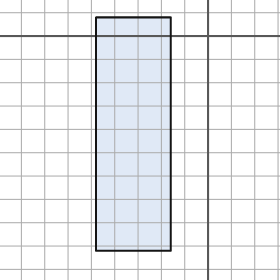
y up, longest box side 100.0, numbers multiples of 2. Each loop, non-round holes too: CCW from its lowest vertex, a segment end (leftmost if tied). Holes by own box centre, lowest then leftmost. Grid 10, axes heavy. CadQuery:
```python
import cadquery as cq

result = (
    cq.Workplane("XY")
    .moveTo(-48.0, -92.0)
    .lineTo(-16.0, -92.0)
    .lineTo(-16.0, 8.0)
    .lineTo(-48.0, 8.0)
    .close()
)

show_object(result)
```